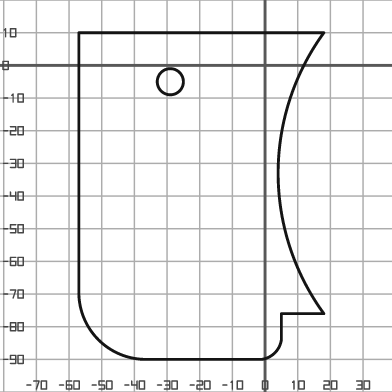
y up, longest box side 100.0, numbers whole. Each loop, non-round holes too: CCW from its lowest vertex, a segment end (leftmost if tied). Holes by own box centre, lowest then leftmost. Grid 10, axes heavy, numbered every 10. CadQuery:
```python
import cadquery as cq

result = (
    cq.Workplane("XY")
    .moveTo(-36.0, -90.0)
    .lineTo(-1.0, -90.0)
    .threePointArc((3.0, -88.0), (5.0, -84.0))
    .lineTo(5.0, -76.0)
    .lineTo(18.0, -76.0)
    .threePointArc((4.0, -33.0), (18.0, 10.0))
    .lineTo(-57.0, 10.0)
    .lineTo(-57.0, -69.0)
    .threePointArc((-51.0, -84.0), (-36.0, -90.0))
    .close()
    .moveTo(-29.0, -5.0)
    .circle(4.0)
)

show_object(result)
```